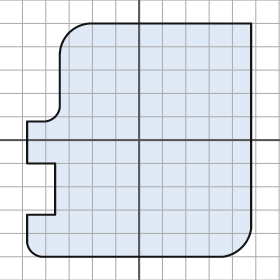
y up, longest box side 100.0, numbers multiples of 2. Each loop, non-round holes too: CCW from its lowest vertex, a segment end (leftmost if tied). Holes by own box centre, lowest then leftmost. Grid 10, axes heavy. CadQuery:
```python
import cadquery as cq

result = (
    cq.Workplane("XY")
    .moveTo(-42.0, -50.0)
    .lineTo(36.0, -50.0)
    .threePointArc((44.0, -46.0), (48.0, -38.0))
    .lineTo(48.0, 50.0)
    .lineTo(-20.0, 50.0)
    .threePointArc((-30.0, 46.0), (-34.0, 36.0))
    .lineTo(-34.0, 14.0)
    .threePointArc((-36.0, 10.0), (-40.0, 8.0))
    .lineTo(-48.0, 8.0)
    .lineTo(-48.0, -10.0)
    .lineTo(-36.0, -10.0)
    .lineTo(-36.0, -32.0)
    .lineTo(-48.0, -32.0)
    .lineTo(-48.0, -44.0)
    .threePointArc((-46.0, -48.0), (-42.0, -50.0))
    .close()
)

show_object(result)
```